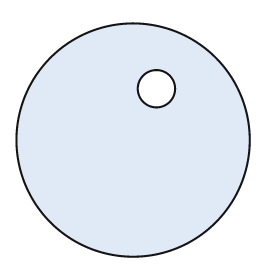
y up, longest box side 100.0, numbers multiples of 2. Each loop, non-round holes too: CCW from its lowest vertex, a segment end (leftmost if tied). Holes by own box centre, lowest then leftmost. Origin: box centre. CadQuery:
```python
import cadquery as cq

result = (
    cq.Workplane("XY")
    .moveTo(0.0, 0.0)
    .circle(50.0)
    .moveTo(10.0, 22.0)
    .circle(8.0)
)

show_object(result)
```